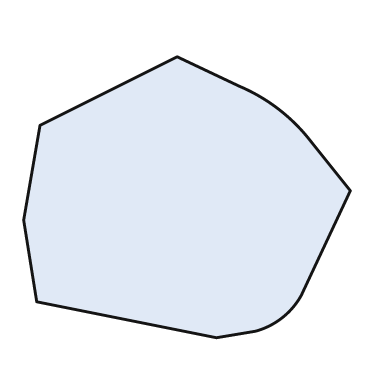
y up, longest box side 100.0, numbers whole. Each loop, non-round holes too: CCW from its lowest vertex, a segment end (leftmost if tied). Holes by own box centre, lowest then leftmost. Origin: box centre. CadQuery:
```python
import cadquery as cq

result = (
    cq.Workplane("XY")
    .moveTo(9.0, -43.0)
    .lineTo(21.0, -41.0)
    .threePointArc((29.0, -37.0), (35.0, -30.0))
    .lineTo(50.0, 2.0)
    .lineTo(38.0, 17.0)
    .threePointArc((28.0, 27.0), (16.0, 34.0))
    .lineTo(-3.0, 43.0)
    .lineTo(-45.0, 22.0)
    .lineTo(-50.0, -7.0)
    .lineTo(-46.0, -32.0)
    .close()
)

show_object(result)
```